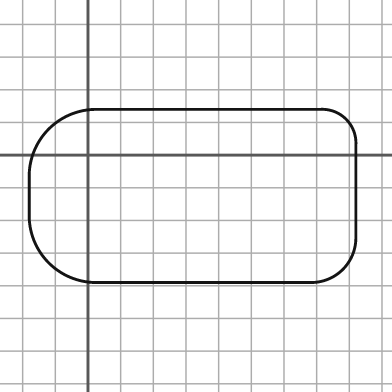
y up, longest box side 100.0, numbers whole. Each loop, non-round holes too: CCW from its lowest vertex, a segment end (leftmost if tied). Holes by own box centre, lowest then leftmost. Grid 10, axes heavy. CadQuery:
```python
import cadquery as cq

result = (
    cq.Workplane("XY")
    .moveTo(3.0, -39.0)
    .lineTo(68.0, -39.0)
    .threePointArc((78.0, -35.0), (82.0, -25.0))
    .lineTo(82.0, 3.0)
    .threePointArc((79.0, 11.0), (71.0, 14.0))
    .lineTo(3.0, 14.0)
    .threePointArc((-12.0, 8.0), (-18.0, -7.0))
    .lineTo(-18.0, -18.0)
    .threePointArc((-12.0, -33.0), (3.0, -39.0))
    .close()
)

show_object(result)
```